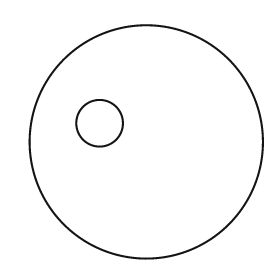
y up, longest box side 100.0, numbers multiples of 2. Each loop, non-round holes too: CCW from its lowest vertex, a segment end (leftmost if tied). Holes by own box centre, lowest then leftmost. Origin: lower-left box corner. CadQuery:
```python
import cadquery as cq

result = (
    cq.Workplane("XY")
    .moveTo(50.0, 50.0)
    .circle(50.0)
    .moveTo(30.0, 58.0)
    .circle(10.0)
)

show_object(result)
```